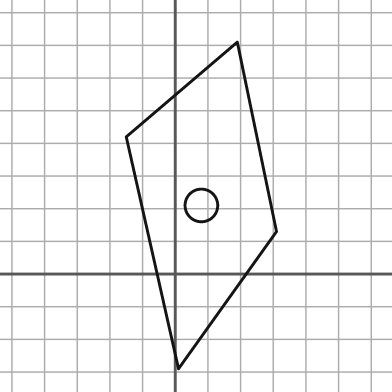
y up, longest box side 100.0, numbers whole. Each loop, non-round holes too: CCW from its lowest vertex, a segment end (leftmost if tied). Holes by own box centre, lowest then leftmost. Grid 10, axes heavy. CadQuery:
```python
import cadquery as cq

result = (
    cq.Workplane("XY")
    .moveTo(1.0, -29.0)
    .lineTo(31.0, 13.0)
    .lineTo(19.0, 71.0)
    .lineTo(-15.0, 42.0)
    .close()
    .moveTo(8.0, 21.0)
    .circle(5.0)
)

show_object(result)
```